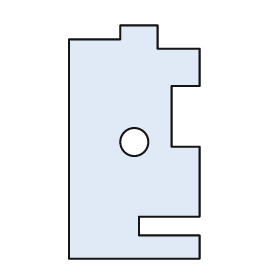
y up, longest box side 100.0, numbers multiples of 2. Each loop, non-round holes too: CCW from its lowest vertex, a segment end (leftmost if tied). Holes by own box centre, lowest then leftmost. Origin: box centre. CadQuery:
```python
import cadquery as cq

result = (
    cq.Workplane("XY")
    .moveTo(-28.0, -50.0)
    .lineTo(28.0, -50.0)
    .lineTo(28.0, -40.0)
    .lineTo(2.0, -40.0)
    .lineTo(2.0, -32.0)
    .lineTo(28.0, -32.0)
    .lineTo(28.0, -2.0)
    .lineTo(16.0, -2.0)
    .lineTo(16.0, 24.0)
    .lineTo(28.0, 24.0)
    .lineTo(28.0, 40.0)
    .lineTo(10.0, 40.0)
    .lineTo(10.0, 50.0)
    .lineTo(-6.0, 50.0)
    .lineTo(-6.0, 44.0)
    .lineTo(-28.0, 44.0)
    .close()
    .moveTo(0.0, 0.0)
    .circle(6.0)
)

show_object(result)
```